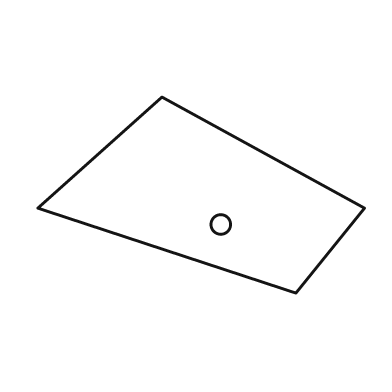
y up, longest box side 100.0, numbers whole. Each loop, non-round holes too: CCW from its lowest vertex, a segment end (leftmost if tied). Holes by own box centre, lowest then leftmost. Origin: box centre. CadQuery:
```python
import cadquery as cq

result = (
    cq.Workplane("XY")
    .moveTo(29.0, -30.0)
    .lineTo(50.0, -4.0)
    .lineTo(-12.0, 30.0)
    .lineTo(-50.0, -4.0)
    .close()
    .moveTo(6.0, -9.0)
    .circle(3.0)
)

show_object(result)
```